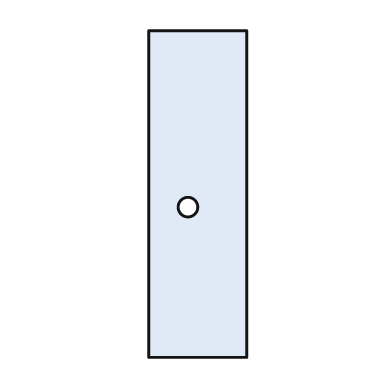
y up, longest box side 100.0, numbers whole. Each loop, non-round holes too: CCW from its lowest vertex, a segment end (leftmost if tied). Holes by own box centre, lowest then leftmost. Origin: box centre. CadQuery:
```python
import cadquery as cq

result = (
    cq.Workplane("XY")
    .moveTo(-15.0, -50.0)
    .lineTo(15.0, -50.0)
    .lineTo(15.0, 50.0)
    .lineTo(-15.0, 50.0)
    .close()
    .moveTo(-3.0, -4.0)
    .circle(3.0)
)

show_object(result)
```